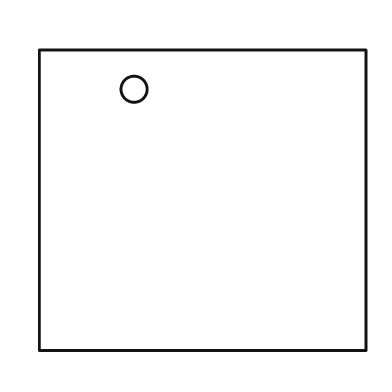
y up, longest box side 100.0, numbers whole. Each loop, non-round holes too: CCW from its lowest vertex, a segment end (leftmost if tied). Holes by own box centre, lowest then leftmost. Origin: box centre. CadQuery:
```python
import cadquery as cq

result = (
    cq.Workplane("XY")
    .moveTo(-50.0, -46.0)
    .lineTo(50.0, -46.0)
    .lineTo(50.0, 46.0)
    .lineTo(-50.0, 46.0)
    .close()
    .moveTo(-21.0, 34.0)
    .circle(4.0)
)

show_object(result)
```